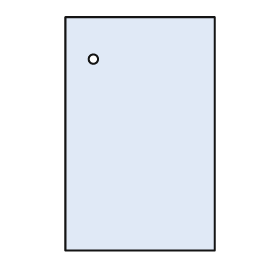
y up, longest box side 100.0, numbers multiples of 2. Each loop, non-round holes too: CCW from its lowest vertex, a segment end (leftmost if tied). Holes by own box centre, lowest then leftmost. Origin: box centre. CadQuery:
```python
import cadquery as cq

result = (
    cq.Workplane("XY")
    .moveTo(-32.0, -50.0)
    .lineTo(32.0, -50.0)
    .lineTo(32.0, 50.0)
    .lineTo(-32.0, 50.0)
    .close()
    .moveTo(-20.0, 32.0)
    .circle(2.0)
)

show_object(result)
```